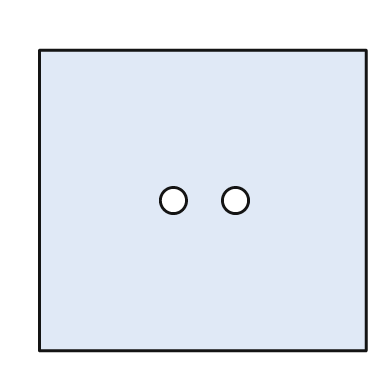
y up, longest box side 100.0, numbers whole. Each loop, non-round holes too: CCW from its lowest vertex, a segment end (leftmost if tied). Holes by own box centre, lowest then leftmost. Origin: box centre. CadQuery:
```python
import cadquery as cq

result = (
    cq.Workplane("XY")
    .moveTo(-50.0, -46.0)
    .lineTo(50.0, -46.0)
    .lineTo(50.0, 46.0)
    .lineTo(-50.0, 46.0)
    .close()
    .moveTo(-9.0, 0.0)
    .circle(4.0)
    .moveTo(10.0, 0.0)
    .circle(4.0)
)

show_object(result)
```